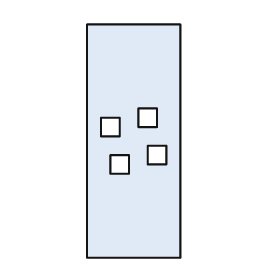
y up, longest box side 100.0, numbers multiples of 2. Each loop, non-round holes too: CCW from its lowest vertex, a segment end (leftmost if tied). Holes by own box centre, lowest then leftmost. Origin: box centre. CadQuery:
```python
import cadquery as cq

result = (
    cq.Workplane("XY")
    .moveTo(-20.0, -50.0)
    .lineTo(20.0, -50.0)
    .lineTo(20.0, 50.0)
    .lineTo(-20.0, 50.0)
    .close()
    .moveTo(-10.0, -14.0)
    .lineTo(-2.0, -14.0)
    .lineTo(-2.0, -6.0)
    .lineTo(-10.0, -6.0)
    .close()
    .moveTo(6.0, -10.0)
    .lineTo(14.0, -10.0)
    .lineTo(14.0, -2.0)
    .lineTo(6.0, -2.0)
    .close()
    .moveTo(-14.0, 2.0)
    .lineTo(-6.0, 2.0)
    .lineTo(-6.0, 10.0)
    .lineTo(-14.0, 10.0)
    .close()
    .moveTo(2.0, 6.0)
    .lineTo(10.0, 6.0)
    .lineTo(10.0, 14.0)
    .lineTo(2.0, 14.0)
    .close()
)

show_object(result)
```